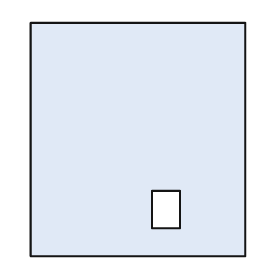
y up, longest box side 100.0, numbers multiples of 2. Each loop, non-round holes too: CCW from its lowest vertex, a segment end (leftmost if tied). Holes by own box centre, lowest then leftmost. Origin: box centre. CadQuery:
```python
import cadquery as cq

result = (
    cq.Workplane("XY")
    .moveTo(-46.0, -50.0)
    .lineTo(46.0, -50.0)
    .lineTo(46.0, 50.0)
    .lineTo(-46.0, 50.0)
    .close()
    .moveTo(6.0, -38.0)
    .lineTo(18.0, -38.0)
    .lineTo(18.0, -22.0)
    .lineTo(6.0, -22.0)
    .close()
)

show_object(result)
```